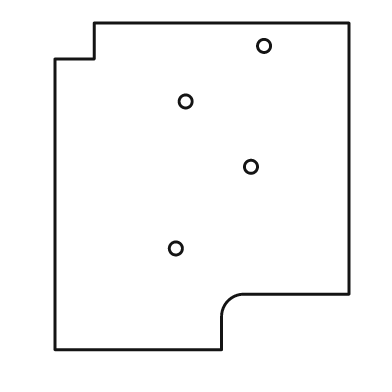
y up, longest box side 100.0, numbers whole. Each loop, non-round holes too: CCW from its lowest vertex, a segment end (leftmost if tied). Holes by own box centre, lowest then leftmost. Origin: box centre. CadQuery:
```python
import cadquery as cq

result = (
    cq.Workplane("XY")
    .moveTo(-45.0, -50.0)
    .lineTo(6.0, -50.0)
    .lineTo(6.0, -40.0)
    .threePointArc((8.0, -35.0), (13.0, -33.0))
    .lineTo(45.0, -33.0)
    .lineTo(45.0, 50.0)
    .lineTo(-33.0, 50.0)
    .lineTo(-33.0, 39.0)
    .lineTo(-45.0, 39.0)
    .close()
    .moveTo(-8.0, -19.0)
    .circle(2.0)
    .moveTo(15.0, 6.0)
    .circle(2.0)
    .moveTo(-5.0, 26.0)
    .circle(2.0)
    .moveTo(19.0, 43.0)
    .circle(2.0)
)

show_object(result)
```